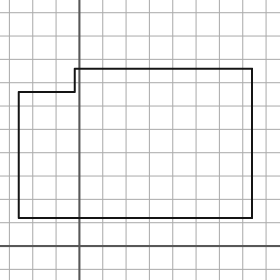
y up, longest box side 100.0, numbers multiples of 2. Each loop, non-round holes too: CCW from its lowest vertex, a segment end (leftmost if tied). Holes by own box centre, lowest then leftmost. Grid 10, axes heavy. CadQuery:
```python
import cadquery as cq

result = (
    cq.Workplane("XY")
    .moveTo(-26.0, 12.0)
    .lineTo(74.0, 12.0)
    .lineTo(74.0, 76.0)
    .lineTo(-2.0, 76.0)
    .lineTo(-2.0, 66.0)
    .lineTo(-26.0, 66.0)
    .close()
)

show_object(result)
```